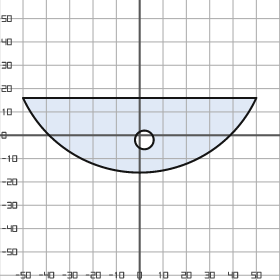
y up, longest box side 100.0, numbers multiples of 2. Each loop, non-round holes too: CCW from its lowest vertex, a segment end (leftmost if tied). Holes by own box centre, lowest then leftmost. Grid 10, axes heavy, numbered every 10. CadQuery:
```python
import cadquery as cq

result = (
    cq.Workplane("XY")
    .moveTo(-50.0, 16.0)
    .threePointArc((0.0, -16.0), (50.0, 16.0))
    .close()
    .moveTo(2.0, -2.0)
    .circle(4.0)
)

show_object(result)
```